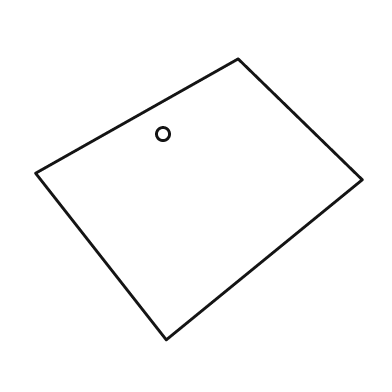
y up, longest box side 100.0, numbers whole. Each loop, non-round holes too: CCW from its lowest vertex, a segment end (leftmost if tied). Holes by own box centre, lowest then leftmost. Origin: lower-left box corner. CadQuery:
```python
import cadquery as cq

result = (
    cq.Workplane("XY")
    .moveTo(40.0, 0.0)
    .lineTo(100.0, 49.0)
    .lineTo(62.0, 86.0)
    .lineTo(0.0, 51.0)
    .close()
    .moveTo(39.0, 63.0)
    .circle(2.0)
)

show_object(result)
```